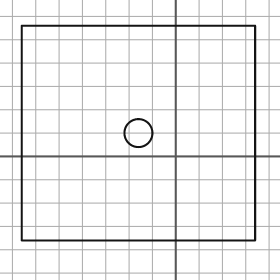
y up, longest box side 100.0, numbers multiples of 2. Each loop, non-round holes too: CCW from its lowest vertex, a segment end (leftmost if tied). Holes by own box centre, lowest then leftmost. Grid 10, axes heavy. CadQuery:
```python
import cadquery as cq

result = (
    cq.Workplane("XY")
    .moveTo(-66.0, -36.0)
    .lineTo(34.0, -36.0)
    .lineTo(34.0, 56.0)
    .lineTo(-66.0, 56.0)
    .close()
    .moveTo(-16.0, 10.0)
    .circle(6.0)
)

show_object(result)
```